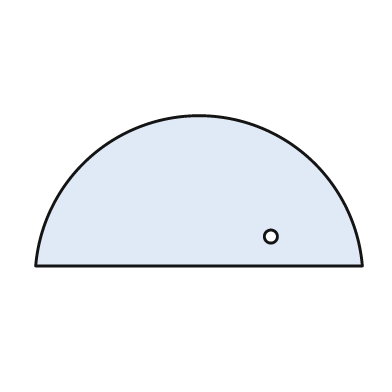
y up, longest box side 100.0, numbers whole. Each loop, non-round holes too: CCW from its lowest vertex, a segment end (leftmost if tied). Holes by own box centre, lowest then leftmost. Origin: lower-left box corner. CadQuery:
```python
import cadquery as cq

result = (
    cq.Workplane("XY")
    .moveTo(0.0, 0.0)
    .lineTo(100.0, 0.0)
    .threePointArc((50.0, 46.0), (0.0, 0.0))
    .close()
    .moveTo(72.0, 9.0)
    .circle(2.0)
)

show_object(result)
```